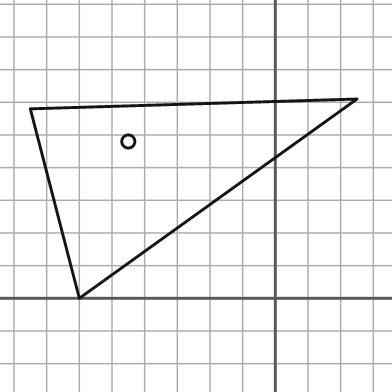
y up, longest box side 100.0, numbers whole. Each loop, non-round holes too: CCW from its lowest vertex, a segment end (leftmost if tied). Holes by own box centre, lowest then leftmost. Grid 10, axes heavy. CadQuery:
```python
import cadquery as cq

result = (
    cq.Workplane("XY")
    .moveTo(-60.0, 0.0)
    .lineTo(25.0, 61.0)
    .lineTo(-75.0, 58.0)
    .close()
    .moveTo(-45.0, 48.0)
    .circle(2.0)
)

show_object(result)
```